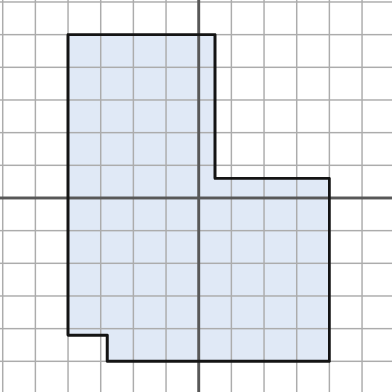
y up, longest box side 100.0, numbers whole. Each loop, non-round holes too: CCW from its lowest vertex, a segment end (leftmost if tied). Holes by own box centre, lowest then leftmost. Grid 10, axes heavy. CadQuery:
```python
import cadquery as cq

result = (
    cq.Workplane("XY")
    .moveTo(-28.0, -50.0)
    .lineTo(40.0, -50.0)
    .lineTo(40.0, 6.0)
    .lineTo(5.0, 6.0)
    .lineTo(5.0, 50.0)
    .lineTo(-40.0, 50.0)
    .lineTo(-40.0, -42.0)
    .lineTo(-28.0, -42.0)
    .close()
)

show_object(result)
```